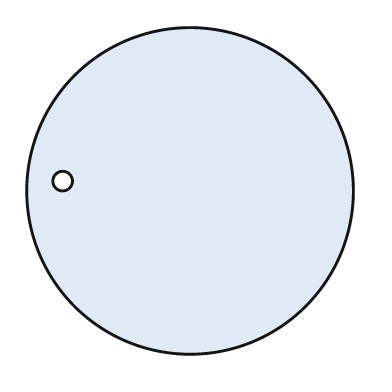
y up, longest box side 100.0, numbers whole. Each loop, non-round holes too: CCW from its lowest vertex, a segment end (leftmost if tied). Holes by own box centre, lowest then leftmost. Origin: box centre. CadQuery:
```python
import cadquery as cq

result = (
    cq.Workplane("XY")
    .moveTo(0.0, 0.0)
    .circle(50.0)
    .moveTo(-39.0, 3.0)
    .circle(3.0)
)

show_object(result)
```